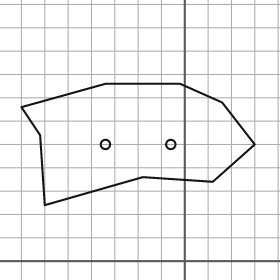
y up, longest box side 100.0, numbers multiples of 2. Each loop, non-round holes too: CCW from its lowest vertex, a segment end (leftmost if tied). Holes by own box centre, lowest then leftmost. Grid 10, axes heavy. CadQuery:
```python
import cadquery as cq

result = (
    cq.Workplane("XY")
    .moveTo(-60.0, 24.0)
    .lineTo(-18.0, 36.0)
    .lineTo(12.0, 34.0)
    .lineTo(30.0, 50.0)
    .lineTo(16.0, 68.0)
    .lineTo(-2.0, 76.0)
    .lineTo(-34.0, 76.0)
    .lineTo(-70.0, 66.0)
    .lineTo(-62.0, 54.0)
    .close()
    .moveTo(-34.0, 50.0)
    .circle(2.0)
    .moveTo(-6.0, 50.0)
    .circle(2.0)
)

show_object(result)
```